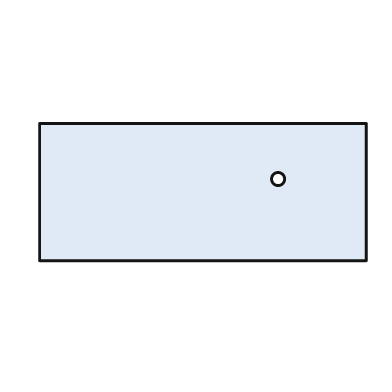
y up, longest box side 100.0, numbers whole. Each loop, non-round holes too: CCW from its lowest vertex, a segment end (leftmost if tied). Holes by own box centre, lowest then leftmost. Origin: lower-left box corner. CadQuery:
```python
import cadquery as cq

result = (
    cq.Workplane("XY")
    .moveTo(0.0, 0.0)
    .lineTo(100.0, 0.0)
    .lineTo(100.0, 42.0)
    .lineTo(0.0, 42.0)
    .close()
    .moveTo(73.0, 25.0)
    .circle(2.0)
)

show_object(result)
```